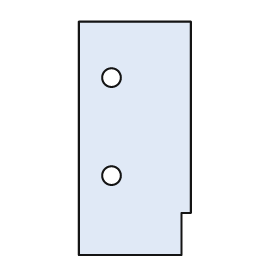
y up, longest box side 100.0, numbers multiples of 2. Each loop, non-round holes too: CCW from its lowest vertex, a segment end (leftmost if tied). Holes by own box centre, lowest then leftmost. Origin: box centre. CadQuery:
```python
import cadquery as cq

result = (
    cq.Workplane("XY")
    .moveTo(-24.0, -50.0)
    .lineTo(20.0, -50.0)
    .lineTo(20.0, -32.0)
    .lineTo(24.0, -32.0)
    .lineTo(24.0, 50.0)
    .lineTo(-24.0, 50.0)
    .close()
    .moveTo(-10.0, -16.0)
    .circle(4.0)
    .moveTo(-10.0, 26.0)
    .circle(4.0)
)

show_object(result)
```